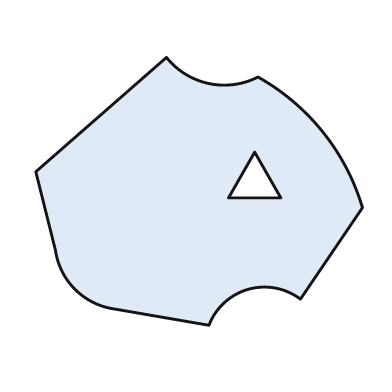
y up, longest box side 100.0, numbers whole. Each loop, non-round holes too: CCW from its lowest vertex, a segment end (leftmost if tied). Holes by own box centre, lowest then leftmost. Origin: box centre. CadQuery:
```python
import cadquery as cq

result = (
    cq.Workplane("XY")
    .moveTo(3.0, -41.0)
    .threePointArc((15.0, -30.0), (31.0, -33.0))
    .lineTo(50.0, -5.0)
    .threePointArc((38.0, 18.0), (18.0, 35.0))
    .threePointArc((3.0, 33.0), (-10.0, 41.0))
    .lineTo(-50.0, 6.0)
    .lineTo(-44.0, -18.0)
    .threePointArc((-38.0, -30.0), (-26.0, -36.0))
    .close()
    .moveTo(9.0, -2.0)
    .lineTo(25.0, -2.0)
    .lineTo(17.0, 12.0)
    .close()
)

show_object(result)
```